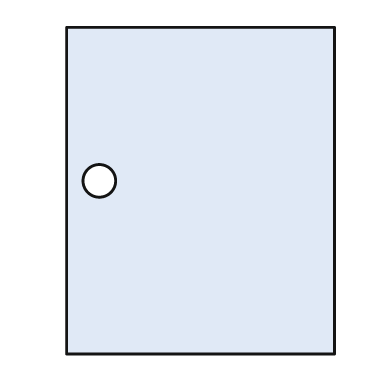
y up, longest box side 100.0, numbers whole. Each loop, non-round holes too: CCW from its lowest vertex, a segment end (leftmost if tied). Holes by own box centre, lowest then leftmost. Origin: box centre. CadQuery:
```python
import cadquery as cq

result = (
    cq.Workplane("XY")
    .moveTo(-41.0, -50.0)
    .lineTo(41.0, -50.0)
    .lineTo(41.0, 50.0)
    .lineTo(-41.0, 50.0)
    .close()
    .moveTo(-31.0, 3.0)
    .circle(5.0)
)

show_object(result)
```